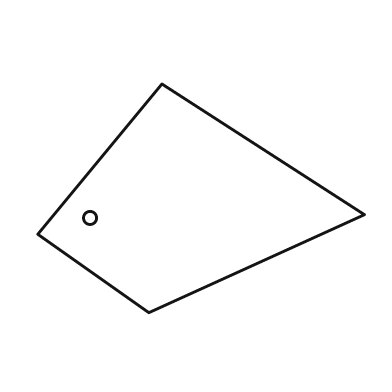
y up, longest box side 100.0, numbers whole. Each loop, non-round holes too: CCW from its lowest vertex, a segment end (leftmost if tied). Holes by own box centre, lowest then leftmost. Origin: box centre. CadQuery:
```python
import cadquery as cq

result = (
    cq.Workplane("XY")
    .moveTo(-16.0, -35.0)
    .lineTo(50.0, -5.0)
    .lineTo(-12.0, 35.0)
    .lineTo(-50.0, -11.0)
    .close()
    .moveTo(-34.0, -6.0)
    .circle(2.0)
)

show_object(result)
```